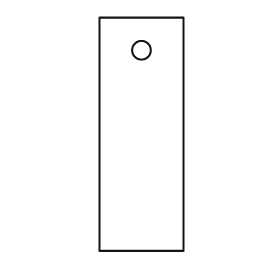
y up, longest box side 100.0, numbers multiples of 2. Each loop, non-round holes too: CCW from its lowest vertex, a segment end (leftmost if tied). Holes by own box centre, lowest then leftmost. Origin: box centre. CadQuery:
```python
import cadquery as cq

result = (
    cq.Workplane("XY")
    .moveTo(-18.0, -50.0)
    .lineTo(18.0, -50.0)
    .lineTo(18.0, 50.0)
    .lineTo(-18.0, 50.0)
    .close()
    .moveTo(0.0, 36.0)
    .circle(4.0)
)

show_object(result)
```